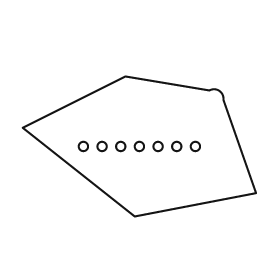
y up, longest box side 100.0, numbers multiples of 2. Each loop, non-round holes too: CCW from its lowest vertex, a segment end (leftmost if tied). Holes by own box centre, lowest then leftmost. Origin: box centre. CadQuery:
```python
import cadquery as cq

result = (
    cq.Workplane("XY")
    .moveTo(-2.0, -30.0)
    .lineTo(50.0, -20.0)
    .lineTo(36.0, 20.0)
    .threePointArc((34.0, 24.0), (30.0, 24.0))
    .lineTo(-6.0, 30.0)
    .lineTo(-50.0, 8.0)
    .close()
    .moveTo(-24.0, 0.0)
    .circle(2.0)
    .moveTo(-16.0, 0.0)
    .circle(2.0)
    .moveTo(-8.0, 0.0)
    .circle(2.0)
    .moveTo(0.0, 0.0)
    .circle(2.0)
    .moveTo(8.0, 0.0)
    .circle(2.0)
    .moveTo(16.0, 0.0)
    .circle(2.0)
    .moveTo(24.0, 0.0)
    .circle(2.0)
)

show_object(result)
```